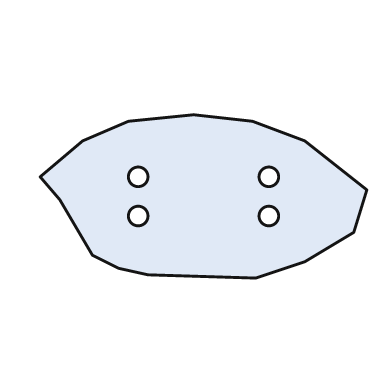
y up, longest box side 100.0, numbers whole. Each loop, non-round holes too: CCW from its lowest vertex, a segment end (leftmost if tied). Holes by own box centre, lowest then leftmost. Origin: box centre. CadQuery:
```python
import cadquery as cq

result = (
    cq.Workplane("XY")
    .moveTo(16.0, -25.0)
    .lineTo(31.0, -20.0)
    .lineTo(46.0, -11.0)
    .lineTo(50.0, 2.0)
    .lineTo(31.0, 17.0)
    .lineTo(15.0, 23.0)
    .lineTo(-3.0, 25.0)
    .lineTo(-23.0, 23.0)
    .lineTo(-37.0, 17.0)
    .lineTo(-50.0, 6.0)
    .lineTo(-44.0, -1.0)
    .lineTo(-34.0, -18.0)
    .lineTo(-26.0, -22.0)
    .lineTo(-17.0, -24.0)
    .close()
    .moveTo(-20.0, -6.0)
    .circle(3.0)
    .moveTo(20.0, -6.0)
    .circle(3.0)
    .moveTo(-20.0, 6.0)
    .circle(3.0)
    .moveTo(20.0, 6.0)
    .circle(3.0)
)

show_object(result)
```